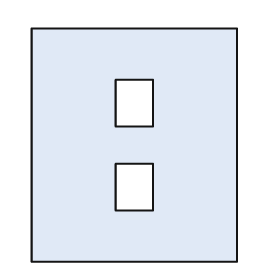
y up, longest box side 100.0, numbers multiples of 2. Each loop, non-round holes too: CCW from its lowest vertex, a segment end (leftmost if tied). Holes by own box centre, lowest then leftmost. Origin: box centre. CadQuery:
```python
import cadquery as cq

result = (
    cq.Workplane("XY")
    .moveTo(-44.0, -50.0)
    .lineTo(44.0, -50.0)
    .lineTo(44.0, 50.0)
    .lineTo(-44.0, 50.0)
    .close()
    .moveTo(-8.0, -28.0)
    .lineTo(8.0, -28.0)
    .lineTo(8.0, -8.0)
    .lineTo(-8.0, -8.0)
    .close()
    .moveTo(-8.0, 8.0)
    .lineTo(8.0, 8.0)
    .lineTo(8.0, 28.0)
    .lineTo(-8.0, 28.0)
    .close()
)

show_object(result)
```